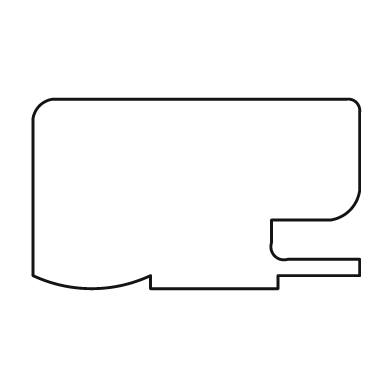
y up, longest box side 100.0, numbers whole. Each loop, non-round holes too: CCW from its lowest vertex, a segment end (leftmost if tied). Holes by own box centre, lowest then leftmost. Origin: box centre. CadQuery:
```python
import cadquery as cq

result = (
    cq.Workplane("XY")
    .moveTo(-14.0, -29.0)
    .lineTo(25.0, -29.0)
    .lineTo(25.0, -25.0)
    .lineTo(50.0, -25.0)
    .lineTo(50.0, -20.0)
    .lineTo(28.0, -20.0)
    .threePointArc((24.0, -19.0), (23.0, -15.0))
    .lineTo(23.0, -8.0)
    .lineTo(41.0, -8.0)
    .threePointArc((47.0, -5.0), (50.0, 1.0))
    .lineTo(50.0, 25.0)
    .threePointArc((49.0, 28.0), (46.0, 29.0))
    .lineTo(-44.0, 29.0)
    .threePointArc((-48.0, 27.0), (-50.0, 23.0))
    .lineTo(-50.0, -25.0)
    .threePointArc((-32.0, -29.0), (-14.0, -25.0))
    .close()
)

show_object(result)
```